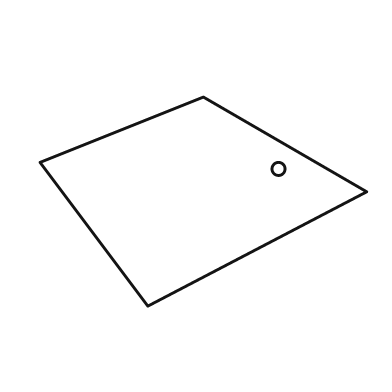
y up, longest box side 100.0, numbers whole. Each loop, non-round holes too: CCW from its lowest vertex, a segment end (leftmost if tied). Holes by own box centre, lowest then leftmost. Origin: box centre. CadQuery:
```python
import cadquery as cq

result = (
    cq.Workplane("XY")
    .moveTo(-17.0, -32.0)
    .lineTo(50.0, 3.0)
    .lineTo(0.0, 32.0)
    .lineTo(-50.0, 12.0)
    .close()
    .moveTo(23.0, 10.0)
    .circle(2.0)
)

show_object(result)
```